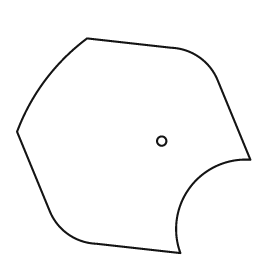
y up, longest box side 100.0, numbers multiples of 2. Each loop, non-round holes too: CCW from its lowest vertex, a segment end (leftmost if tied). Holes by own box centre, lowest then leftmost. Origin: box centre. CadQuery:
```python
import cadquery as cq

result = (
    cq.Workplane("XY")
    .moveTo(20.0, -46.0)
    .threePointArc((24.0, -18.0), (50.0, -6.0))
    .lineTo(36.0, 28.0)
    .threePointArc((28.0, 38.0), (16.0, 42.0))
    .lineTo(-20.0, 46.0)
    .threePointArc((-38.0, 28.0), (-50.0, 6.0))
    .lineTo(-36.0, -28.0)
    .threePointArc((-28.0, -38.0), (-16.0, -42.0))
    .close()
    .moveTo(12.0, 2.0)
    .circle(2.0)
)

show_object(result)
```